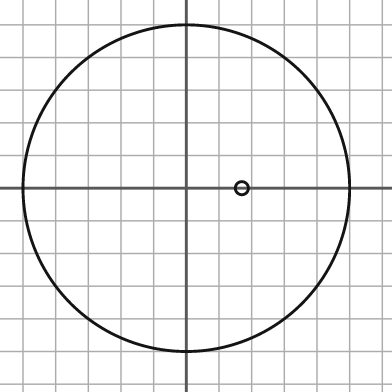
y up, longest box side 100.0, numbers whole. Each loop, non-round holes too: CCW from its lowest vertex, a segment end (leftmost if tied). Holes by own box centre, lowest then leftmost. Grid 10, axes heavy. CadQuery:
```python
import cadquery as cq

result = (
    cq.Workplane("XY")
    .moveTo(0.0, 0.0)
    .circle(50.0)
    .moveTo(17.0, 0.0)
    .circle(2.0)
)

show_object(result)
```